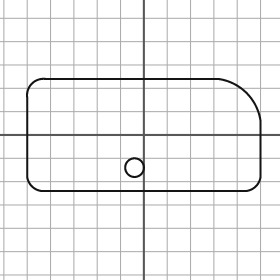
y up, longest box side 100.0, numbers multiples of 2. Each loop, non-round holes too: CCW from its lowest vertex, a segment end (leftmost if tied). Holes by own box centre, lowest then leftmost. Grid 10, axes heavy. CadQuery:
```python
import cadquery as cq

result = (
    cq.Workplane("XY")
    .moveTo(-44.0, -24.0)
    .lineTo(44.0, -24.0)
    .threePointArc((48.0, -22.0), (50.0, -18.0))
    .lineTo(50.0, 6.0)
    .threePointArc((44.0, 18.0), (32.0, 24.0))
    .lineTo(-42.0, 24.0)
    .threePointArc((-48.0, 22.0), (-50.0, 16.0))
    .lineTo(-50.0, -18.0)
    .threePointArc((-48.0, -22.0), (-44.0, -24.0))
    .close()
    .moveTo(-4.0, -14.0)
    .circle(4.0)
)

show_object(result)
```